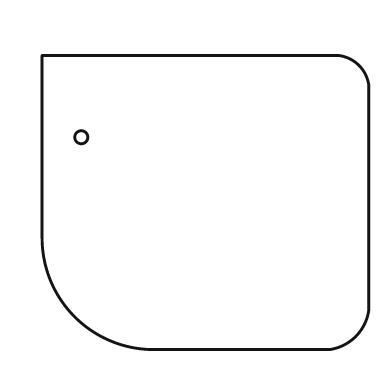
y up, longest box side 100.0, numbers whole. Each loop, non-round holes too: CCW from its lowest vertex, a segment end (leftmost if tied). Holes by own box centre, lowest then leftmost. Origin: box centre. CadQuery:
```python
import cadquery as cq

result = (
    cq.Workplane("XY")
    .moveTo(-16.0, -45.0)
    .lineTo(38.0, -45.0)
    .threePointArc((46.0, -41.0), (50.0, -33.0))
    .lineTo(50.0, 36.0)
    .threePointArc((47.0, 42.0), (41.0, 45.0))
    .lineTo(-50.0, 45.0)
    .lineTo(-50.0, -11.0)
    .threePointArc((-40.0, -35.0), (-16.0, -45.0))
    .close()
    .moveTo(-38.0, 20.0)
    .circle(2.0)
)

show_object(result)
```